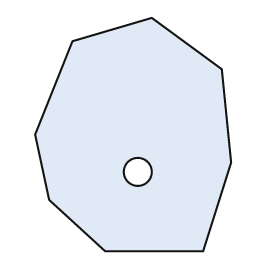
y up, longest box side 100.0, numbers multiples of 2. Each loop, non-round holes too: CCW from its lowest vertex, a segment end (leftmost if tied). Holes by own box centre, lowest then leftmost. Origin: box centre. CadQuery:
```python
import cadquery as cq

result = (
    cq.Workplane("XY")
    .moveTo(-12.0, -50.0)
    .lineTo(30.0, -50.0)
    .lineTo(42.0, -12.0)
    .lineTo(38.0, 28.0)
    .lineTo(8.0, 50.0)
    .lineTo(-26.0, 40.0)
    .lineTo(-42.0, 0.0)
    .lineTo(-36.0, -28.0)
    .close()
    .moveTo(2.0, -16.0)
    .circle(6.0)
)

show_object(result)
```